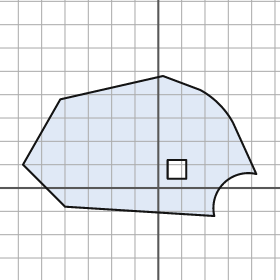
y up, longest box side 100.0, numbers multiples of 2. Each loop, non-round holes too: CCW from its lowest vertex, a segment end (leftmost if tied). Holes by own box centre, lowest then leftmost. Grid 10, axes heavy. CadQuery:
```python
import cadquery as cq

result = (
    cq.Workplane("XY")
    .moveTo(24.0, -12.0)
    .threePointArc((28.0, 2.0), (42.0, 6.0))
    .lineTo(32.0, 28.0)
    .threePointArc((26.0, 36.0), (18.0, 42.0))
    .lineTo(2.0, 48.0)
    .lineTo(-42.0, 38.0)
    .lineTo(-58.0, 10.0)
    .lineTo(-40.0, -8.0)
    .close()
    .moveTo(4.0, 4.0)
    .lineTo(12.0, 4.0)
    .lineTo(12.0, 12.0)
    .lineTo(4.0, 12.0)
    .close()
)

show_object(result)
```